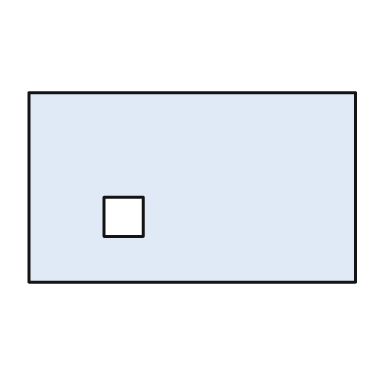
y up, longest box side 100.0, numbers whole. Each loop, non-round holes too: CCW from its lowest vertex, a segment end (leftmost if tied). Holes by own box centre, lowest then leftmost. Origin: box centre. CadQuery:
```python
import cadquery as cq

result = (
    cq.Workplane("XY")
    .moveTo(-50.0, -29.0)
    .lineTo(50.0, -29.0)
    .lineTo(50.0, 29.0)
    .lineTo(-50.0, 29.0)
    .close()
    .moveTo(-27.0, -15.0)
    .lineTo(-15.0, -15.0)
    .lineTo(-15.0, -3.0)
    .lineTo(-27.0, -3.0)
    .close()
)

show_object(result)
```